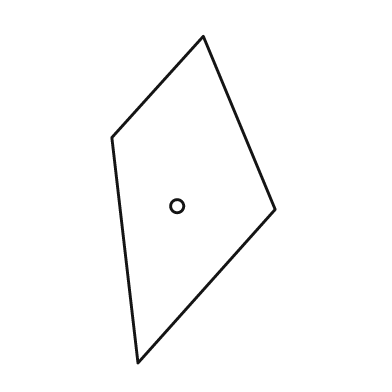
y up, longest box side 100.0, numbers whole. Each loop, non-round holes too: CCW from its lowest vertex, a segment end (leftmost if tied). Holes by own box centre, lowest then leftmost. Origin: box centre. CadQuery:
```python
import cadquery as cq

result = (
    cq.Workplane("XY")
    .moveTo(-17.0, -50.0)
    .lineTo(25.0, -3.0)
    .lineTo(3.0, 50.0)
    .lineTo(-25.0, 19.0)
    .close()
    .moveTo(-5.0, -2.0)
    .circle(2.0)
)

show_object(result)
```